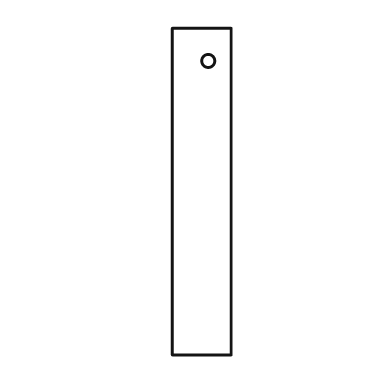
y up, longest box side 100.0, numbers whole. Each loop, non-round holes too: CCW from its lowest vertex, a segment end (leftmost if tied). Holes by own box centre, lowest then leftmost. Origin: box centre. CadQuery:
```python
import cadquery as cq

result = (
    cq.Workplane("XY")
    .moveTo(-9.0, -50.0)
    .lineTo(9.0, -50.0)
    .lineTo(9.0, 50.0)
    .lineTo(-9.0, 50.0)
    .close()
    .moveTo(2.0, 40.0)
    .circle(2.0)
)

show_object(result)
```